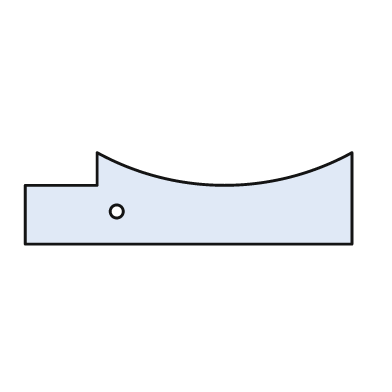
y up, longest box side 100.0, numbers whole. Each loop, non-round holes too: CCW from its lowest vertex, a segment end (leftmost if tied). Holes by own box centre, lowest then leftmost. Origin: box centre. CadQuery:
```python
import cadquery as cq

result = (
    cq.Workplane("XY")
    .moveTo(-50.0, -14.0)
    .lineTo(50.0, -14.0)
    .lineTo(50.0, 14.0)
    .threePointArc((11.0, 4.0), (-28.0, 14.0))
    .lineTo(-28.0, 4.0)
    .lineTo(-50.0, 4.0)
    .close()
    .moveTo(-22.0, -4.0)
    .circle(2.0)
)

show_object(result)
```